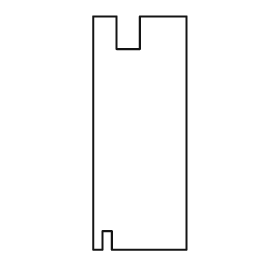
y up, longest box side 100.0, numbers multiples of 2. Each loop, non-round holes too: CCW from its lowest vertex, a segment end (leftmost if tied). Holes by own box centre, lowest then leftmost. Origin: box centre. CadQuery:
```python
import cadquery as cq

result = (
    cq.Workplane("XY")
    .moveTo(-20.0, -50.0)
    .lineTo(-16.0, -50.0)
    .lineTo(-16.0, -42.0)
    .lineTo(-12.0, -42.0)
    .lineTo(-12.0, -50.0)
    .lineTo(20.0, -50.0)
    .lineTo(20.0, 50.0)
    .lineTo(0.0, 50.0)
    .lineTo(0.0, 36.0)
    .lineTo(-10.0, 36.0)
    .lineTo(-10.0, 50.0)
    .lineTo(-20.0, 50.0)
    .close()
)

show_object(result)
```